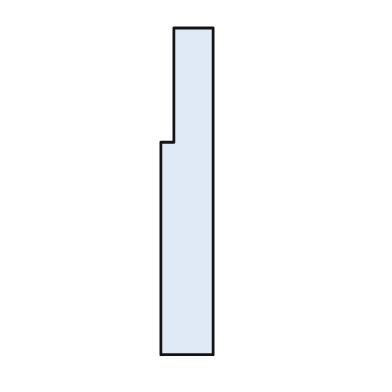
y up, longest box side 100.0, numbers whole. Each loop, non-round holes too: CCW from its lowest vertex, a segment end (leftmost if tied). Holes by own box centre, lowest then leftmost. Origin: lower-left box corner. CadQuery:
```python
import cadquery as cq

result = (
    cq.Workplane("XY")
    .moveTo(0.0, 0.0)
    .lineTo(16.0, 0.0)
    .lineTo(16.0, 100.0)
    .lineTo(4.0, 100.0)
    .lineTo(4.0, 65.0)
    .lineTo(0.0, 65.0)
    .close()
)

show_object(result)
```